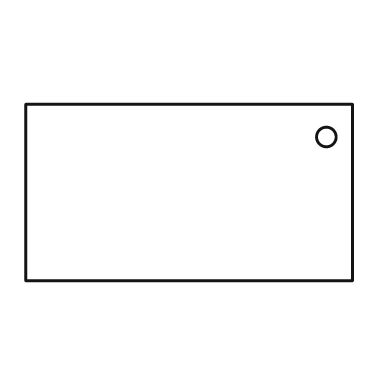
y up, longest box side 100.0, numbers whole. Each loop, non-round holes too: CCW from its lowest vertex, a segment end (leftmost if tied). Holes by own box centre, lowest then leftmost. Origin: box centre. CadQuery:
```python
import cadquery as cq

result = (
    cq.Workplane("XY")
    .moveTo(-50.0, -27.0)
    .lineTo(50.0, -27.0)
    .lineTo(50.0, 27.0)
    .lineTo(-50.0, 27.0)
    .close()
    .moveTo(42.0, 17.0)
    .circle(3.0)
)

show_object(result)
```